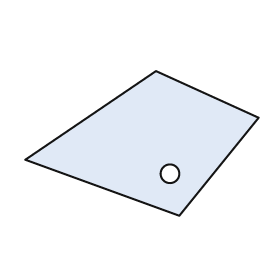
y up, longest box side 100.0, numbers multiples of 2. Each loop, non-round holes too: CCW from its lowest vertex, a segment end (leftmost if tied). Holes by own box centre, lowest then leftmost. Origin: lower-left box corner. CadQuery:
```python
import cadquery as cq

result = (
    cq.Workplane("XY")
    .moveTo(66.0, 0.0)
    .lineTo(100.0, 42.0)
    .lineTo(56.0, 62.0)
    .lineTo(0.0, 24.0)
    .close()
    .moveTo(62.0, 18.0)
    .circle(4.0)
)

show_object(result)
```